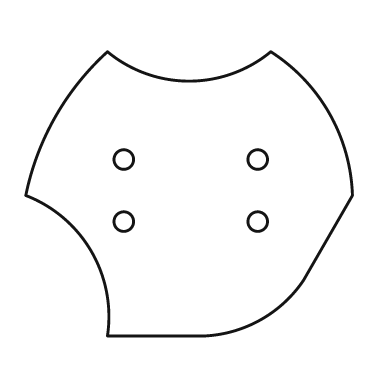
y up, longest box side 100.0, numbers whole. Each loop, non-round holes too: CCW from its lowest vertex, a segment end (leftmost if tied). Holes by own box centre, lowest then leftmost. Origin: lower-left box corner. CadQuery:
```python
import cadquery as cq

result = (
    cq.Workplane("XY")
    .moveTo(25.0, 0.0)
    .lineTo(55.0, 0.0)
    .threePointArc((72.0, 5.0), (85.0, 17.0))
    .lineTo(100.0, 43.0)
    .threePointArc((93.0, 68.0), (75.0, 87.0))
    .threePointArc((50.0, 78.0), (25.0, 87.0))
    .threePointArc((9.0, 67.0), (0.0, 43.0))
    .threePointArc((20.0, 26.0), (25.0, 0.0))
    .close()
    .moveTo(30.0, 35.0)
    .circle(3.0)
    .moveTo(71.0, 35.0)
    .circle(3.0)
    .moveTo(30.0, 54.0)
    .circle(3.0)
    .moveTo(71.0, 54.0)
    .circle(3.0)
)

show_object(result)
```